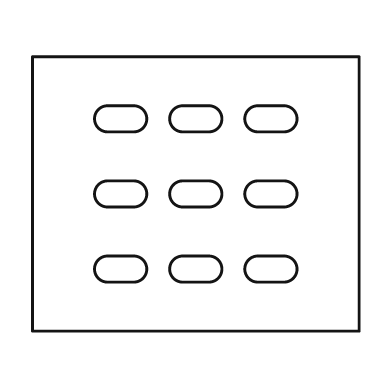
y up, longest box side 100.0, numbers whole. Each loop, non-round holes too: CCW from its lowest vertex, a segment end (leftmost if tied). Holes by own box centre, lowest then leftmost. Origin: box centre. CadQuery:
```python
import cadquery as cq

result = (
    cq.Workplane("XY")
    .moveTo(-50.0, -42.0)
    .lineTo(50.0, -42.0)
    .lineTo(50.0, 42.0)
    .lineTo(-50.0, 42.0)
    .close()
    .moveTo(-27.0, -27.0)
    .lineTo(-19.0, -27.0)
    .threePointArc((-15.0, -23.0), (-19.0, -19.0))
    .lineTo(-27.0, -19.0)
    .threePointArc((-31.0, -23.0), (-27.0, -27.0))
    .close()
    .moveTo(-4.0, -27.0)
    .lineTo(4.0, -27.0)
    .threePointArc((8.0, -23.0), (4.0, -19.0))
    .lineTo(-4.0, -19.0)
    .threePointArc((-8.0, -23.0), (-4.0, -27.0))
    .close()
    .moveTo(19.0, -27.0)
    .lineTo(27.0, -27.0)
    .threePointArc((31.0, -23.0), (27.0, -19.0))
    .lineTo(19.0, -19.0)
    .threePointArc((15.0, -23.0), (19.0, -27.0))
    .close()
    .moveTo(-27.0, -4.0)
    .lineTo(-19.0, -4.0)
    .threePointArc((-15.0, 0.0), (-19.0, 4.0))
    .lineTo(-27.0, 4.0)
    .threePointArc((-31.0, 0.0), (-27.0, -4.0))
    .close()
    .moveTo(-4.0, -4.0)
    .lineTo(4.0, -4.0)
    .threePointArc((8.0, 0.0), (4.0, 4.0))
    .lineTo(-4.0, 4.0)
    .threePointArc((-8.0, 0.0), (-4.0, -4.0))
    .close()
    .moveTo(19.0, -4.0)
    .lineTo(27.0, -4.0)
    .threePointArc((31.0, 0.0), (27.0, 4.0))
    .lineTo(19.0, 4.0)
    .threePointArc((15.0, 0.0), (19.0, -4.0))
    .close()
    .moveTo(-27.0, 19.0)
    .lineTo(-19.0, 19.0)
    .threePointArc((-15.0, 23.0), (-19.0, 27.0))
    .lineTo(-27.0, 27.0)
    .threePointArc((-31.0, 23.0), (-27.0, 19.0))
    .close()
    .moveTo(-4.0, 19.0)
    .lineTo(4.0, 19.0)
    .threePointArc((8.0, 23.0), (4.0, 27.0))
    .lineTo(-4.0, 27.0)
    .threePointArc((-8.0, 23.0), (-4.0, 19.0))
    .close()
    .moveTo(19.0, 19.0)
    .lineTo(27.0, 19.0)
    .threePointArc((31.0, 23.0), (27.0, 27.0))
    .lineTo(19.0, 27.0)
    .threePointArc((15.0, 23.0), (19.0, 19.0))
    .close()
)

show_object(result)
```